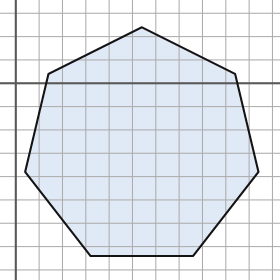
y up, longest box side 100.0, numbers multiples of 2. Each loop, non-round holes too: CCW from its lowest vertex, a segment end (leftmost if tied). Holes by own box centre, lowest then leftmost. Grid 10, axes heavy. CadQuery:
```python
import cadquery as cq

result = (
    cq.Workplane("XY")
    .moveTo(32.0, -74.0)
    .lineTo(76.0, -74.0)
    .lineTo(104.0, -38.0)
    .lineTo(94.0, 4.0)
    .lineTo(54.0, 24.0)
    .lineTo(14.0, 4.0)
    .lineTo(4.0, -38.0)
    .close()
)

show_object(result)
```